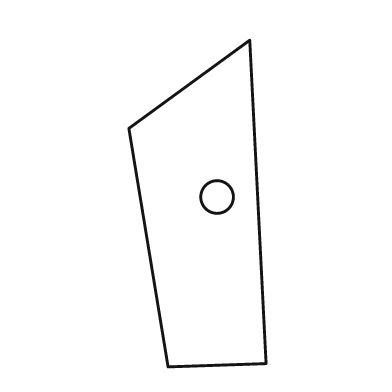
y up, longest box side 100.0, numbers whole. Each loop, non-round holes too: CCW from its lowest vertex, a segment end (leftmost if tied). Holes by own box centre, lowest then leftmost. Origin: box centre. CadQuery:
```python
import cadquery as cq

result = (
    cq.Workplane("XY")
    .moveTo(-9.0, -50.0)
    .lineTo(21.0, -49.0)
    .lineTo(16.0, 50.0)
    .lineTo(-21.0, 23.0)
    .close()
    .moveTo(6.0, 2.0)
    .circle(5.0)
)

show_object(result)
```